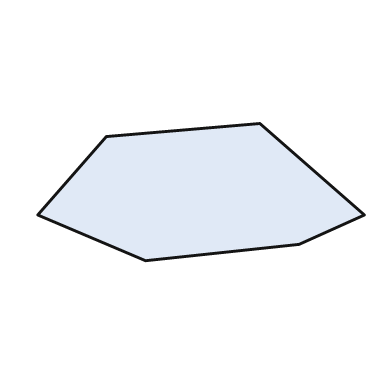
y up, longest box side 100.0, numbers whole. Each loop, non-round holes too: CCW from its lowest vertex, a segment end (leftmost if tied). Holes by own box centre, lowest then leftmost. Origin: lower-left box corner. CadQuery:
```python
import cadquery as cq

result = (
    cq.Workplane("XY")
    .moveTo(33.0, 0.0)
    .lineTo(80.0, 5.0)
    .lineTo(100.0, 14.0)
    .lineTo(68.0, 42.0)
    .lineTo(21.0, 38.0)
    .lineTo(0.0, 14.0)
    .close()
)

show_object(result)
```